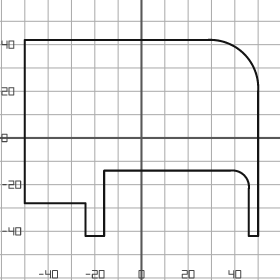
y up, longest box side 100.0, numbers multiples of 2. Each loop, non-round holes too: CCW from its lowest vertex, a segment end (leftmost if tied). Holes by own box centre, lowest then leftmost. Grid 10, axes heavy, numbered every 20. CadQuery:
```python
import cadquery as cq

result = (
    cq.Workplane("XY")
    .moveTo(-24.0, -42.0)
    .lineTo(-16.0, -42.0)
    .lineTo(-16.0, -14.0)
    .lineTo(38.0, -14.0)
    .threePointArc((44.0, -16.0), (46.0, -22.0))
    .lineTo(46.0, -42.0)
    .lineTo(50.0, -42.0)
    .lineTo(50.0, 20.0)
    .threePointArc((44.0, 36.0), (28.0, 42.0))
    .lineTo(-50.0, 42.0)
    .lineTo(-50.0, -28.0)
    .lineTo(-24.0, -28.0)
    .close()
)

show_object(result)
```